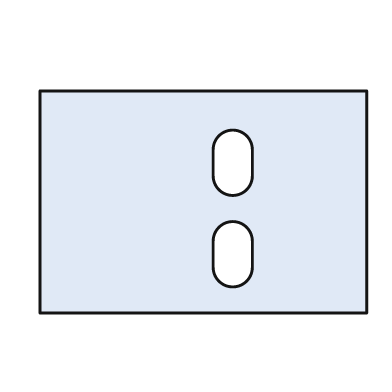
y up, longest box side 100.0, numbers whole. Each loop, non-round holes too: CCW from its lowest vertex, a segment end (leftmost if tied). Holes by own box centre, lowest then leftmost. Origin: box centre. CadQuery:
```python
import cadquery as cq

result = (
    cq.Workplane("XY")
    .moveTo(-50.0, -34.0)
    .lineTo(50.0, -34.0)
    .lineTo(50.0, 34.0)
    .lineTo(-50.0, 34.0)
    .close()
    .moveTo(3.0, -20.0)
    .threePointArc((9.0, -26.0), (15.0, -20.0))
    .lineTo(15.0, -12.0)
    .threePointArc((9.0, -6.0), (3.0, -12.0))
    .close()
    .moveTo(3.0, 8.0)
    .threePointArc((9.0, 2.0), (15.0, 8.0))
    .lineTo(15.0, 16.0)
    .threePointArc((9.0, 22.0), (3.0, 16.0))
    .close()
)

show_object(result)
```